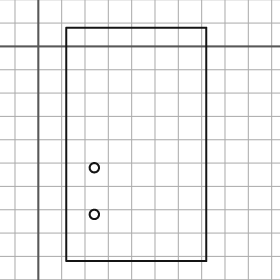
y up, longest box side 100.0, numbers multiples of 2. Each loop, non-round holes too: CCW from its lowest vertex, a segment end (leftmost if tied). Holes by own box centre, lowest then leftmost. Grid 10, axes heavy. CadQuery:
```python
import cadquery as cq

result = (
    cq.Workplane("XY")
    .moveTo(12.0, -92.0)
    .lineTo(72.0, -92.0)
    .lineTo(72.0, 8.0)
    .lineTo(12.0, 8.0)
    .close()
    .moveTo(24.0, -72.0)
    .circle(2.0)
    .moveTo(24.0, -52.0)
    .circle(2.0)
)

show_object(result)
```